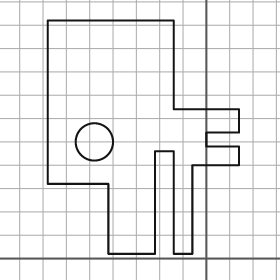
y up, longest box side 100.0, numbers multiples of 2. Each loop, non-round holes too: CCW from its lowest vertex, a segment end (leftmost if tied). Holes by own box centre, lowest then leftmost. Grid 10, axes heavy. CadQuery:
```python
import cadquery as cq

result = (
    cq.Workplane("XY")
    .moveTo(-42.0, 2.0)
    .lineTo(-22.0, 2.0)
    .lineTo(-22.0, 46.0)
    .lineTo(-14.0, 46.0)
    .lineTo(-14.0, 2.0)
    .lineTo(-6.0, 2.0)
    .lineTo(-6.0, 40.0)
    .lineTo(14.0, 40.0)
    .lineTo(14.0, 48.0)
    .lineTo(0.0, 48.0)
    .lineTo(0.0, 54.0)
    .lineTo(14.0, 54.0)
    .lineTo(14.0, 64.0)
    .lineTo(-14.0, 64.0)
    .lineTo(-14.0, 102.0)
    .lineTo(-68.0, 102.0)
    .lineTo(-68.0, 32.0)
    .lineTo(-42.0, 32.0)
    .close()
    .moveTo(-48.0, 50.0)
    .circle(8.0)
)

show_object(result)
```